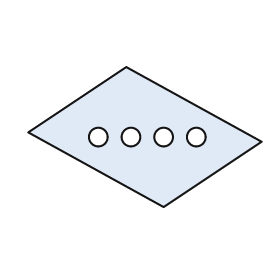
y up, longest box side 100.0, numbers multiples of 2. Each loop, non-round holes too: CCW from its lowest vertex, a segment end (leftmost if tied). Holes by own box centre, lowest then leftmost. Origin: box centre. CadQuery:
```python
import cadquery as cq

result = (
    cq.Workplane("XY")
    .moveTo(8.0, -30.0)
    .lineTo(50.0, -2.0)
    .lineTo(-8.0, 30.0)
    .lineTo(-50.0, 2.0)
    .close()
    .moveTo(-20.0, 0.0)
    .circle(4.0)
    .moveTo(-6.0, 0.0)
    .circle(4.0)
    .moveTo(8.0, 0.0)
    .circle(4.0)
    .moveTo(22.0, 0.0)
    .circle(4.0)
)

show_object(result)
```